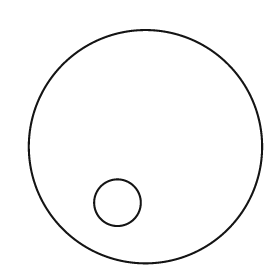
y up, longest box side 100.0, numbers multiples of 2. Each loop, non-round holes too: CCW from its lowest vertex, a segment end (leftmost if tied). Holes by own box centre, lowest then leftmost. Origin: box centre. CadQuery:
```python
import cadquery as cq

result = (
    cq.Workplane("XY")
    .moveTo(0.0, 0.0)
    .circle(50.0)
    .moveTo(-12.0, -24.0)
    .circle(10.0)
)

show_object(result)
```